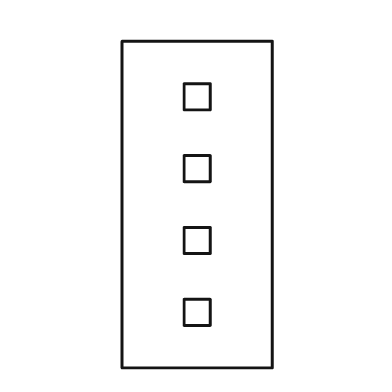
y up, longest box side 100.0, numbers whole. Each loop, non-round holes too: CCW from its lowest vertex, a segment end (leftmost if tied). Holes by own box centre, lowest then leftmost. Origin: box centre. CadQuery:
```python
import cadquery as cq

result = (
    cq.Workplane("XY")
    .moveTo(-23.0, -50.0)
    .lineTo(23.0, -50.0)
    .lineTo(23.0, 50.0)
    .lineTo(-23.0, 50.0)
    .close()
    .moveTo(-4.0, -37.0)
    .lineTo(4.0, -37.0)
    .lineTo(4.0, -29.0)
    .lineTo(-4.0, -29.0)
    .close()
    .moveTo(-4.0, -15.0)
    .lineTo(4.0, -15.0)
    .lineTo(4.0, -7.0)
    .lineTo(-4.0, -7.0)
    .close()
    .moveTo(-4.0, 7.0)
    .lineTo(4.0, 7.0)
    .lineTo(4.0, 15.0)
    .lineTo(-4.0, 15.0)
    .close()
    .moveTo(-4.0, 29.0)
    .lineTo(4.0, 29.0)
    .lineTo(4.0, 37.0)
    .lineTo(-4.0, 37.0)
    .close()
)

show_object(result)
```